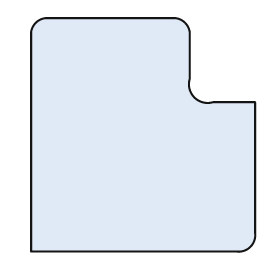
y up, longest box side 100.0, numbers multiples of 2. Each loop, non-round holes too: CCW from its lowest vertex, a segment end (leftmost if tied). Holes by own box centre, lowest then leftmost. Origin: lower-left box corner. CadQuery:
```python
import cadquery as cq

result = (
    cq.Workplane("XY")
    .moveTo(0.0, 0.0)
    .lineTo(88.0, 0.0)
    .threePointArc((94.0, 2.0), (96.0, 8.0))
    .lineTo(96.0, 64.0)
    .lineTo(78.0, 64.0)
    .threePointArc((70.0, 66.0), (68.0, 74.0))
    .lineTo(68.0, 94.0)
    .threePointArc((66.0, 98.0), (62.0, 100.0))
    .lineTo(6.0, 100.0)
    .threePointArc((2.0, 98.0), (0.0, 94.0))
    .close()
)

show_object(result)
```